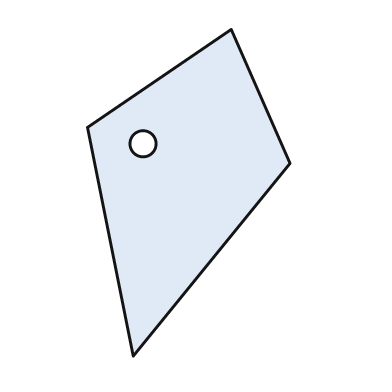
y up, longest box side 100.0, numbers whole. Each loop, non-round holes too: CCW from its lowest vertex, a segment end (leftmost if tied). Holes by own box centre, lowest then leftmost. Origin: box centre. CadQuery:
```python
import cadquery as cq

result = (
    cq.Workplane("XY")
    .moveTo(-17.0, -50.0)
    .lineTo(31.0, 9.0)
    .lineTo(13.0, 50.0)
    .lineTo(-31.0, 20.0)
    .close()
    .moveTo(-14.0, 15.0)
    .circle(4.0)
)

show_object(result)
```